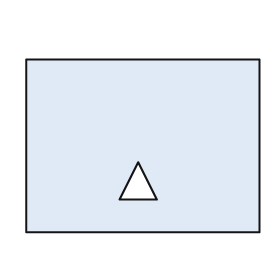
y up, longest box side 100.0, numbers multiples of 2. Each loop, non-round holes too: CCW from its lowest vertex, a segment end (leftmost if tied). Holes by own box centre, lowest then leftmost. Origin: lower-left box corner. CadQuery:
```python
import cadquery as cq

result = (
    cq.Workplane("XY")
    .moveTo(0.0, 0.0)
    .lineTo(100.0, 0.0)
    .lineTo(100.0, 74.0)
    .lineTo(0.0, 74.0)
    .close()
    .moveTo(40.0, 14.0)
    .lineTo(56.0, 14.0)
    .lineTo(48.0, 30.0)
    .close()
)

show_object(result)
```